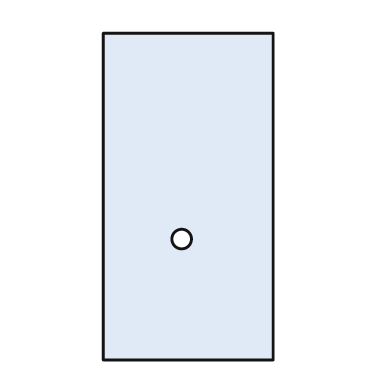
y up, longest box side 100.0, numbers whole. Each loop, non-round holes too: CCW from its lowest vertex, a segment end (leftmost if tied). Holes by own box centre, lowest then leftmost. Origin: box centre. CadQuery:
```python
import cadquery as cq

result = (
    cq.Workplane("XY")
    .moveTo(-26.0, -50.0)
    .lineTo(26.0, -50.0)
    .lineTo(26.0, 50.0)
    .lineTo(-26.0, 50.0)
    .close()
    .moveTo(-2.0, -13.0)
    .circle(3.0)
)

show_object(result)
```